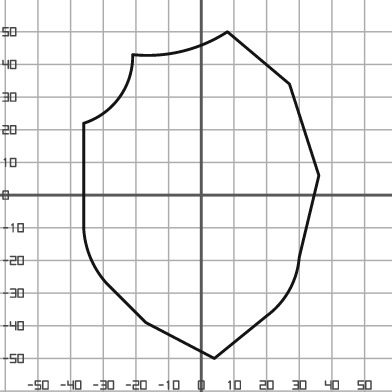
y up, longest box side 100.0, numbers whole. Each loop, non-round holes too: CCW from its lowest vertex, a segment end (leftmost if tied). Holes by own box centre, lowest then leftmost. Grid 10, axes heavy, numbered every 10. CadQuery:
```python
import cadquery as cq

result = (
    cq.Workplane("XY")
    .moveTo(4.0, -50.0)
    .lineTo(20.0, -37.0)
    .threePointArc((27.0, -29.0), (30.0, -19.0))
    .lineTo(36.0, 6.0)
    .lineTo(27.0, 34.0)
    .lineTo(8.0, 50.0)
    .threePointArc((-6.0, 44.0), (-21.0, 43.0))
    .threePointArc((-25.0, 30.0), (-36.0, 22.0))
    .lineTo(-36.0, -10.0)
    .threePointArc((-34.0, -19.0), (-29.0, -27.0))
    .lineTo(-17.0, -39.0)
    .close()
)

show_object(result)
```